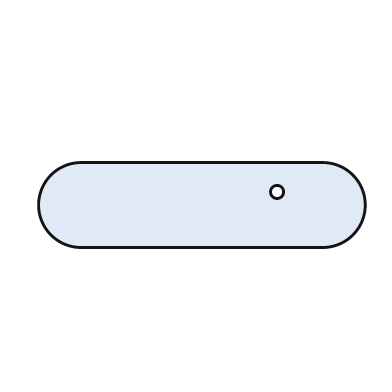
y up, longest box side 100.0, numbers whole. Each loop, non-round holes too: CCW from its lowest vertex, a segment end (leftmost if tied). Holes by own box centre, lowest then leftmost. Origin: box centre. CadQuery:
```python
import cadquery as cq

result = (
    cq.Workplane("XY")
    .moveTo(-37.0, -13.0)
    .lineTo(37.0, -13.0)
    .threePointArc((50.0, 0.0), (37.0, 13.0))
    .lineTo(-37.0, 13.0)
    .threePointArc((-50.0, 0.0), (-37.0, -13.0))
    .close()
    .moveTo(23.0, 4.0)
    .circle(2.0)
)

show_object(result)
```